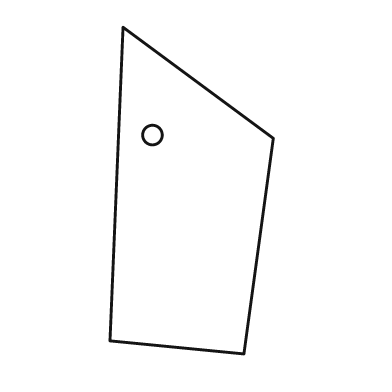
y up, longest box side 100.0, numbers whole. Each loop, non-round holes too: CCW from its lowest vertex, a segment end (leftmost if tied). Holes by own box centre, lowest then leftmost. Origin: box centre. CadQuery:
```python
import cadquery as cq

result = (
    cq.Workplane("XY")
    .moveTo(16.0, -50.0)
    .lineTo(25.0, 16.0)
    .lineTo(-21.0, 50.0)
    .lineTo(-25.0, -46.0)
    .close()
    .moveTo(-12.0, 17.0)
    .circle(3.0)
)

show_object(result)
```